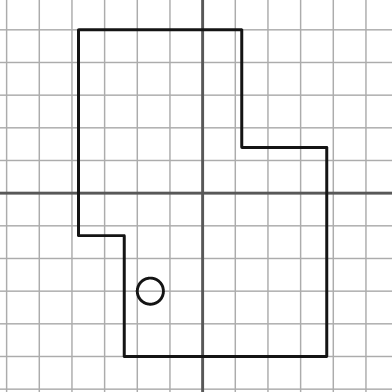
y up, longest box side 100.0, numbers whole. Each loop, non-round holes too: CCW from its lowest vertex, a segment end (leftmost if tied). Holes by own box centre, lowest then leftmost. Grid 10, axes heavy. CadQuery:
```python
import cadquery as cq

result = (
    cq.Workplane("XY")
    .moveTo(-24.0, -50.0)
    .lineTo(38.0, -50.0)
    .lineTo(38.0, 14.0)
    .lineTo(12.0, 14.0)
    .lineTo(12.0, 50.0)
    .lineTo(-38.0, 50.0)
    .lineTo(-38.0, -13.0)
    .lineTo(-24.0, -13.0)
    .close()
    .moveTo(-16.0, -30.0)
    .circle(4.0)
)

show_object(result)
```